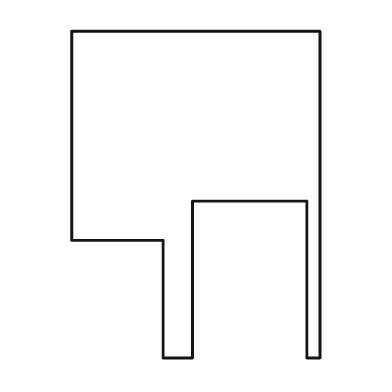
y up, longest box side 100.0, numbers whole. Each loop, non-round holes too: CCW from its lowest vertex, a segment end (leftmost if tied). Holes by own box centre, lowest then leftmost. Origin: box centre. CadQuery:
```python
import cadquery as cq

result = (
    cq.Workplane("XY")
    .moveTo(-10.0, -50.0)
    .lineTo(-1.0, -50.0)
    .lineTo(-1.0, -2.0)
    .lineTo(34.0, -2.0)
    .lineTo(34.0, -50.0)
    .lineTo(38.0, -50.0)
    .lineTo(38.0, 50.0)
    .lineTo(-38.0, 50.0)
    .lineTo(-38.0, -14.0)
    .lineTo(-10.0, -14.0)
    .close()
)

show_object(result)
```